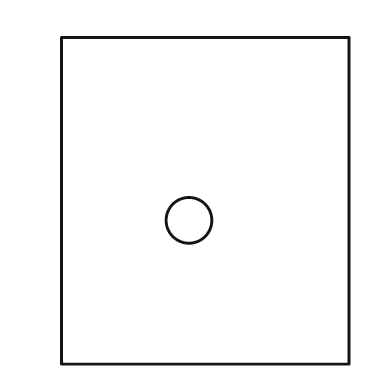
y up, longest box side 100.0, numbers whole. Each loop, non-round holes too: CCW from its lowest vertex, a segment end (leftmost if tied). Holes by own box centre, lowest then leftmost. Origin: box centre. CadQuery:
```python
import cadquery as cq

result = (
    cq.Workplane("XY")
    .moveTo(-44.0, -50.0)
    .lineTo(44.0, -50.0)
    .lineTo(44.0, 50.0)
    .lineTo(-44.0, 50.0)
    .close()
    .moveTo(-5.0, -6.0)
    .circle(7.0)
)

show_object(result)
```